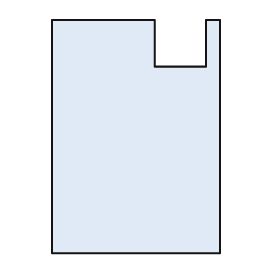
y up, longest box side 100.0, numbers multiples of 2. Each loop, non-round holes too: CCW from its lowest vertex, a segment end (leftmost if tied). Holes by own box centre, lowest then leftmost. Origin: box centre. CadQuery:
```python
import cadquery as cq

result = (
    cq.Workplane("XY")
    .moveTo(-36.0, -50.0)
    .lineTo(36.0, -50.0)
    .lineTo(36.0, 50.0)
    .lineTo(30.0, 50.0)
    .lineTo(30.0, 30.0)
    .lineTo(8.0, 30.0)
    .lineTo(8.0, 50.0)
    .lineTo(-36.0, 50.0)
    .close()
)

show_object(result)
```